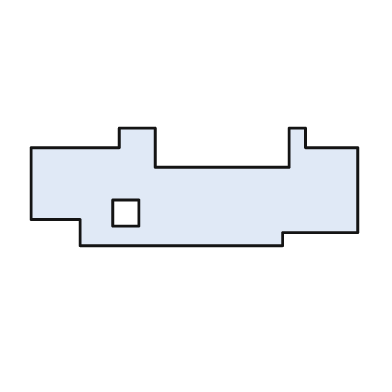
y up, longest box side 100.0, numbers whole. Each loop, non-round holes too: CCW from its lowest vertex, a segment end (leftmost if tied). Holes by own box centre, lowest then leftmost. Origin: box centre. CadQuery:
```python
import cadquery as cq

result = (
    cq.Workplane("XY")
    .moveTo(-35.0, -18.0)
    .lineTo(27.0, -18.0)
    .lineTo(27.0, -14.0)
    .lineTo(50.0, -14.0)
    .lineTo(50.0, 12.0)
    .lineTo(34.0, 12.0)
    .lineTo(34.0, 18.0)
    .lineTo(29.0, 18.0)
    .lineTo(29.0, 6.0)
    .lineTo(-12.0, 6.0)
    .lineTo(-12.0, 18.0)
    .lineTo(-23.0, 18.0)
    .lineTo(-23.0, 12.0)
    .lineTo(-50.0, 12.0)
    .lineTo(-50.0, -10.0)
    .lineTo(-35.0, -10.0)
    .close()
    .moveTo(-25.0, -12.0)
    .lineTo(-17.0, -12.0)
    .lineTo(-17.0, -4.0)
    .lineTo(-25.0, -4.0)
    .close()
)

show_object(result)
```